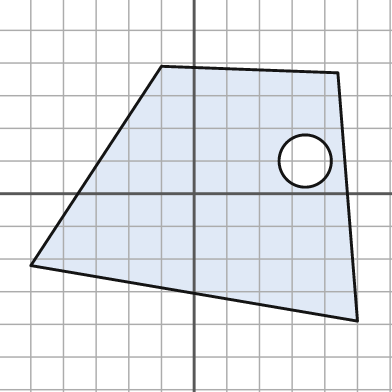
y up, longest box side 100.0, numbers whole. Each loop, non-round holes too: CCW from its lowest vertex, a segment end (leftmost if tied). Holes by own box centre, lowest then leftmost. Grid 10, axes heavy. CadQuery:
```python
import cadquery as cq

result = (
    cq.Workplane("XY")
    .moveTo(50.0, -39.0)
    .lineTo(44.0, 37.0)
    .lineTo(-10.0, 39.0)
    .lineTo(-50.0, -22.0)
    .close()
    .moveTo(34.0, 10.0)
    .circle(8.0)
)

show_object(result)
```